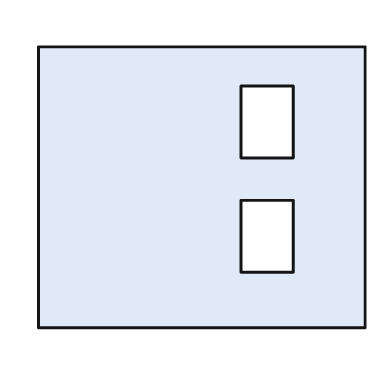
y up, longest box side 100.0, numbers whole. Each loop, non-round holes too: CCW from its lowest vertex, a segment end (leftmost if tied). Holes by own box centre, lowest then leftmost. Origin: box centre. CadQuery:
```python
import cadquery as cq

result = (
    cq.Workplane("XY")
    .moveTo(-50.0, -43.0)
    .lineTo(50.0, -43.0)
    .lineTo(50.0, 43.0)
    .lineTo(-50.0, 43.0)
    .close()
    .moveTo(12.0, -26.0)
    .lineTo(28.0, -26.0)
    .lineTo(28.0, -4.0)
    .lineTo(12.0, -4.0)
    .close()
    .moveTo(12.0, 9.0)
    .lineTo(28.0, 9.0)
    .lineTo(28.0, 31.0)
    .lineTo(12.0, 31.0)
    .close()
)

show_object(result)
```